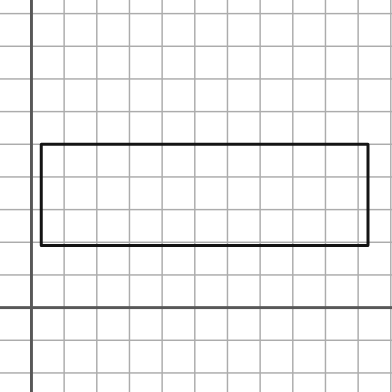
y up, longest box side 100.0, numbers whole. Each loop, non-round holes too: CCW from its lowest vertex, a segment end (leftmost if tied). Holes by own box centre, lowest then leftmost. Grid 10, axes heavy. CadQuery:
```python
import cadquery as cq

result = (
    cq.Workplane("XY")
    .moveTo(3.0, 19.0)
    .lineTo(103.0, 19.0)
    .lineTo(103.0, 50.0)
    .lineTo(3.0, 50.0)
    .close()
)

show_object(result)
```